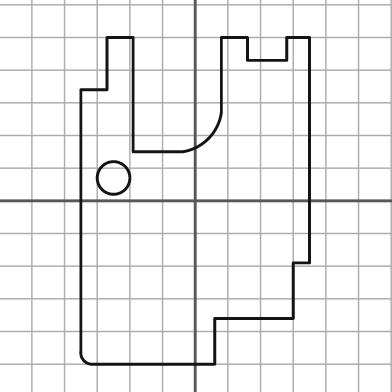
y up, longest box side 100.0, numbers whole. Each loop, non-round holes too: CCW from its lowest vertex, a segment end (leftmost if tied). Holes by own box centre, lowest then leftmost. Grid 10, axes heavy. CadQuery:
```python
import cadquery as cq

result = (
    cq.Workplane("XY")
    .moveTo(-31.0, -50.0)
    .lineTo(6.0, -50.0)
    .lineTo(6.0, -36.0)
    .lineTo(30.0, -36.0)
    .lineTo(30.0, -19.0)
    .lineTo(35.0, -19.0)
    .lineTo(35.0, 50.0)
    .lineTo(28.0, 50.0)
    .lineTo(28.0, 43.0)
    .lineTo(16.0, 43.0)
    .lineTo(16.0, 50.0)
    .lineTo(8.0, 50.0)
    .lineTo(8.0, 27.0)
    .threePointArc((4.0, 19.0), (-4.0, 15.0))
    .lineTo(-19.0, 15.0)
    .lineTo(-19.0, 50.0)
    .lineTo(-27.0, 50.0)
    .lineTo(-27.0, 34.0)
    .lineTo(-35.0, 34.0)
    .lineTo(-35.0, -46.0)
    .threePointArc((-34.0, -49.0), (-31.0, -50.0))
    .close()
    .moveTo(-25.0, 7.0)
    .circle(5.0)
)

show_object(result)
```